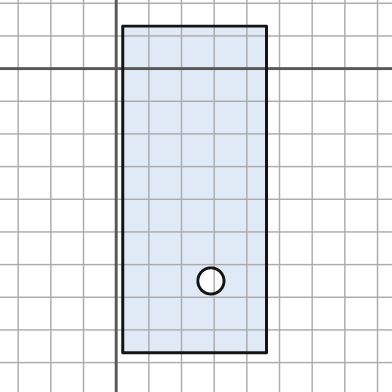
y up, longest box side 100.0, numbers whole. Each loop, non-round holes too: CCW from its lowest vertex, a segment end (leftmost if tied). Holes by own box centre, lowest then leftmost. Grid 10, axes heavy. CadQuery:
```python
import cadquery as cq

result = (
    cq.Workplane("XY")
    .moveTo(2.0, -87.0)
    .lineTo(46.0, -87.0)
    .lineTo(46.0, 13.0)
    .lineTo(2.0, 13.0)
    .close()
    .moveTo(29.0, -65.0)
    .circle(4.0)
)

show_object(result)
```